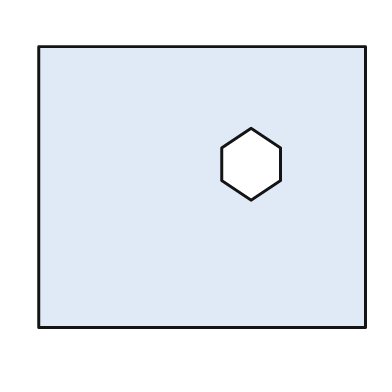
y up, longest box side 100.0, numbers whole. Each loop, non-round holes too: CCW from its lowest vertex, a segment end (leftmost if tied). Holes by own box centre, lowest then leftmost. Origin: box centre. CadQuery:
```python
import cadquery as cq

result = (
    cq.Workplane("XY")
    .moveTo(-50.0, -43.0)
    .lineTo(50.0, -43.0)
    .lineTo(50.0, 43.0)
    .lineTo(-50.0, 43.0)
    .close()
    .moveTo(15.0, -4.0)
    .lineTo(24.0, 2.0)
    .lineTo(24.0, 12.0)
    .lineTo(15.0, 18.0)
    .lineTo(6.0, 12.0)
    .lineTo(6.0, 2.0)
    .close()
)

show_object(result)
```